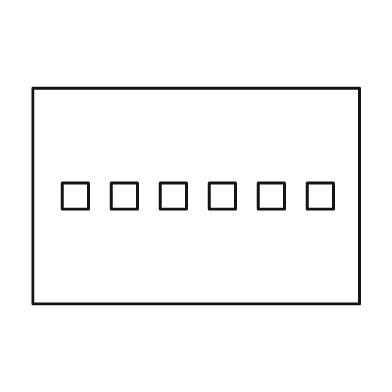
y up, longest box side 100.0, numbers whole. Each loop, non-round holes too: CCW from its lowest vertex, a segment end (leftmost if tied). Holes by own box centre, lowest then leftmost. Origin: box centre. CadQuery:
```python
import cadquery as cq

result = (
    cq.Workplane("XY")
    .moveTo(-50.0, -33.0)
    .lineTo(50.0, -33.0)
    .lineTo(50.0, 33.0)
    .lineTo(-50.0, 33.0)
    .close()
    .moveTo(-41.0, -4.0)
    .lineTo(-33.0, -4.0)
    .lineTo(-33.0, 4.0)
    .lineTo(-41.0, 4.0)
    .close()
    .moveTo(-26.0, -4.0)
    .lineTo(-18.0, -4.0)
    .lineTo(-18.0, 4.0)
    .lineTo(-26.0, 4.0)
    .close()
    .moveTo(-11.0, -4.0)
    .lineTo(-3.0, -4.0)
    .lineTo(-3.0, 4.0)
    .lineTo(-11.0, 4.0)
    .close()
    .moveTo(4.0, -4.0)
    .lineTo(12.0, -4.0)
    .lineTo(12.0, 4.0)
    .lineTo(4.0, 4.0)
    .close()
    .moveTo(19.0, -4.0)
    .lineTo(27.0, -4.0)
    .lineTo(27.0, 4.0)
    .lineTo(19.0, 4.0)
    .close()
    .moveTo(34.0, -4.0)
    .lineTo(42.0, -4.0)
    .lineTo(42.0, 4.0)
    .lineTo(34.0, 4.0)
    .close()
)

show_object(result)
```